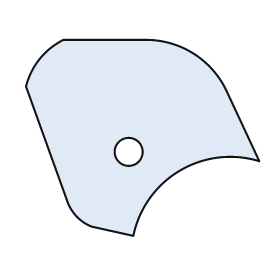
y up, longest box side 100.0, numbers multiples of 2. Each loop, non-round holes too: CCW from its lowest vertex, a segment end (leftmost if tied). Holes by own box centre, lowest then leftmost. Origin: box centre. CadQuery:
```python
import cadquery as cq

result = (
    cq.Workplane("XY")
    .moveTo(-4.0, -42.0)
    .threePointArc((16.0, -14.0), (50.0, -10.0))
    .lineTo(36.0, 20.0)
    .threePointArc((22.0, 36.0), (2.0, 42.0))
    .lineTo(-34.0, 42.0)
    .threePointArc((-44.0, 34.0), (-50.0, 22.0))
    .lineTo(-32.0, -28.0)
    .threePointArc((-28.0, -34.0), (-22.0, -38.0))
    .close()
    .moveTo(-6.0, -6.0)
    .circle(6.0)
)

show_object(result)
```